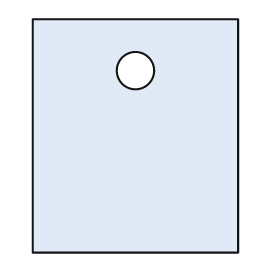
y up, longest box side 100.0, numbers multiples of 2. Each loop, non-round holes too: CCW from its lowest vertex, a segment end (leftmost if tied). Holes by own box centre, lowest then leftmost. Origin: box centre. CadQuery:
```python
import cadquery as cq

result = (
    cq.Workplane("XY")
    .moveTo(-44.0, -50.0)
    .lineTo(44.0, -50.0)
    .lineTo(44.0, 50.0)
    .lineTo(-44.0, 50.0)
    .close()
    .moveTo(0.0, 28.0)
    .circle(8.0)
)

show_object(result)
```